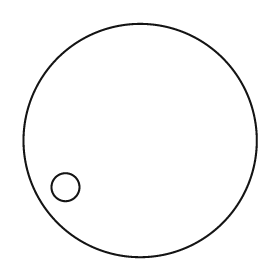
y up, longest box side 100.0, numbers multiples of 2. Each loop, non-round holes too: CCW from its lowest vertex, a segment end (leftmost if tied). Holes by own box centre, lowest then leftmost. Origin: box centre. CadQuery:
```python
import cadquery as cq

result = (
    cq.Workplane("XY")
    .moveTo(0.0, 0.0)
    .circle(50.0)
    .moveTo(-32.0, -20.0)
    .circle(6.0)
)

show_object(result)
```